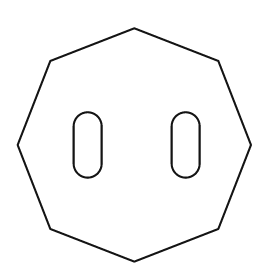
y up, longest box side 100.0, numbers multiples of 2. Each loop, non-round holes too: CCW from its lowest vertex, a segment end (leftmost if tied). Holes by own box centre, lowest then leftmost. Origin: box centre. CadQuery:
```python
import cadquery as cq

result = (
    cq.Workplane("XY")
    .moveTo(0.0, -50.0)
    .lineTo(36.0, -36.0)
    .lineTo(50.0, 0.0)
    .lineTo(36.0, 36.0)
    .lineTo(0.0, 50.0)
    .lineTo(-36.0, 36.0)
    .lineTo(-50.0, 0.0)
    .lineTo(-36.0, -36.0)
    .close()
    .moveTo(-26.0, -8.0)
    .threePointArc((-20.0, -14.0), (-14.0, -8.0))
    .lineTo(-14.0, 8.0)
    .threePointArc((-20.0, 14.0), (-26.0, 8.0))
    .close()
    .moveTo(16.0, -8.0)
    .threePointArc((22.0, -14.0), (28.0, -8.0))
    .lineTo(28.0, 8.0)
    .threePointArc((22.0, 14.0), (16.0, 8.0))
    .close()
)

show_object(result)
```